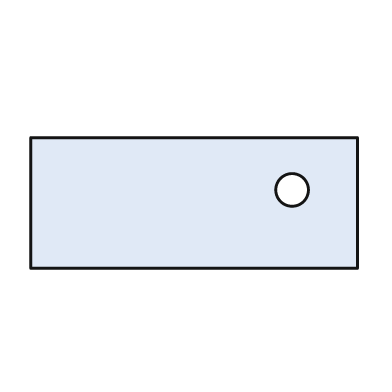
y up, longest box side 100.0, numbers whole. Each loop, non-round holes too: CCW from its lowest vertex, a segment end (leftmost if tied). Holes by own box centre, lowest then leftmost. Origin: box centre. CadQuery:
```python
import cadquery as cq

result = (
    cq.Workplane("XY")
    .moveTo(-50.0, -20.0)
    .lineTo(50.0, -20.0)
    .lineTo(50.0, 20.0)
    .lineTo(-50.0, 20.0)
    .close()
    .moveTo(30.0, 4.0)
    .circle(5.0)
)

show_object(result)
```